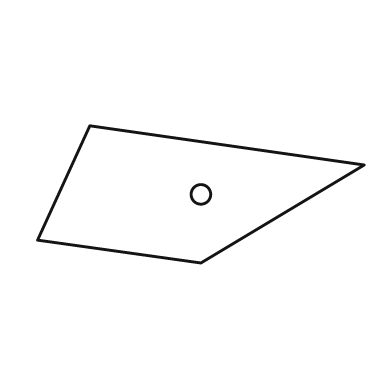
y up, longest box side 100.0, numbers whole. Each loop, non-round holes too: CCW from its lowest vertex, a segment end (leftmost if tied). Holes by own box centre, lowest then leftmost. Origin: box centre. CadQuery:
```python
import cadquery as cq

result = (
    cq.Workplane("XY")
    .moveTo(0.0, -21.0)
    .lineTo(50.0, 9.0)
    .lineTo(-34.0, 21.0)
    .lineTo(-50.0, -14.0)
    .close()
    .moveTo(0.0, 0.0)
    .circle(3.0)
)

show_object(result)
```